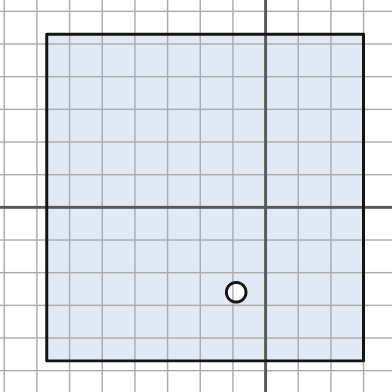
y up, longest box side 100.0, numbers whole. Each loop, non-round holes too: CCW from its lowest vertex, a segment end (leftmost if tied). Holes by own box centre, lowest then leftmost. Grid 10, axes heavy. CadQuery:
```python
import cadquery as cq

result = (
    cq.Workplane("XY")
    .moveTo(-67.0, -47.0)
    .lineTo(30.0, -47.0)
    .lineTo(30.0, 53.0)
    .lineTo(-67.0, 53.0)
    .close()
    .moveTo(-9.0, -26.0)
    .circle(3.0)
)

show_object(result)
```